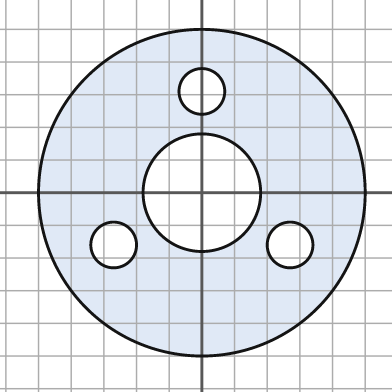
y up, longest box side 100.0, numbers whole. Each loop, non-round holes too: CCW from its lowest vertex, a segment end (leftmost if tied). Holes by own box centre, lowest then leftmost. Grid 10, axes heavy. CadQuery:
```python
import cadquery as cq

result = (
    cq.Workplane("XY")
    .moveTo(0.0, 0.0)
    .circle(50.0)
    .moveTo(-27.0, -16.0)
    .circle(7.0)
    .moveTo(27.0, -16.0)
    .circle(7.0)
    .moveTo(0.0, 0.0)
    .circle(18.0)
    .moveTo(0.0, 31.0)
    .circle(7.0)
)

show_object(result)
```